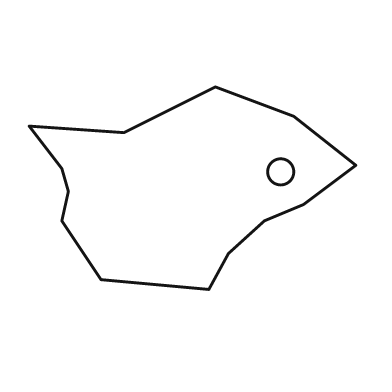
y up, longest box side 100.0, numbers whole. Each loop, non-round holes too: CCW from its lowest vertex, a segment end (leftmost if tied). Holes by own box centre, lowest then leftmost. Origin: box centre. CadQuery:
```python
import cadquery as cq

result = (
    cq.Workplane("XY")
    .moveTo(5.0, -31.0)
    .lineTo(11.0, -20.0)
    .lineTo(22.0, -10.0)
    .lineTo(34.0, -5.0)
    .lineTo(50.0, 7.0)
    .lineTo(31.0, 22.0)
    .lineTo(7.0, 31.0)
    .lineTo(-21.0, 17.0)
    .lineTo(-50.0, 19.0)
    .lineTo(-40.0, 6.0)
    .lineTo(-38.0, -1.0)
    .lineTo(-40.0, -10.0)
    .lineTo(-28.0, -28.0)
    .close()
    .moveTo(27.0, 5.0)
    .circle(4.0)
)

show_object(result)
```